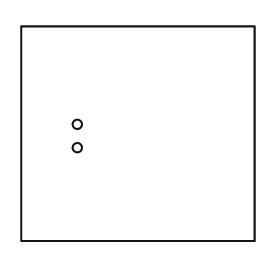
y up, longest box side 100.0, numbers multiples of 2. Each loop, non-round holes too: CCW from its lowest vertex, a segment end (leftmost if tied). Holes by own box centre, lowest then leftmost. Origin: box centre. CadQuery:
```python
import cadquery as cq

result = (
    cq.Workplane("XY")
    .moveTo(-50.0, -46.0)
    .lineTo(50.0, -46.0)
    .lineTo(50.0, 46.0)
    .lineTo(-50.0, 46.0)
    .close()
    .moveTo(-26.0, -6.0)
    .circle(2.0)
    .moveTo(-26.0, 4.0)
    .circle(2.0)
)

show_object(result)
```